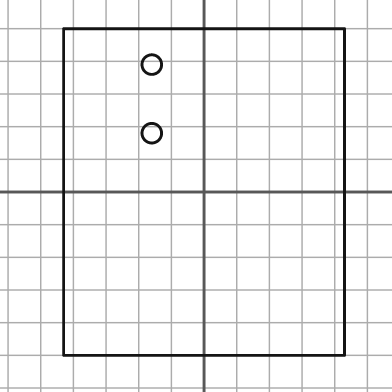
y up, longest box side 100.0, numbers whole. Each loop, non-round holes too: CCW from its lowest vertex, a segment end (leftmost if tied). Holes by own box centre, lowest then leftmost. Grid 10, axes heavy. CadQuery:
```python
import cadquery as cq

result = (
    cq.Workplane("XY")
    .moveTo(-43.0, -50.0)
    .lineTo(43.0, -50.0)
    .lineTo(43.0, 50.0)
    .lineTo(-43.0, 50.0)
    .close()
    .moveTo(-16.0, 18.0)
    .circle(3.0)
    .moveTo(-16.0, 39.0)
    .circle(3.0)
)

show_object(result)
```